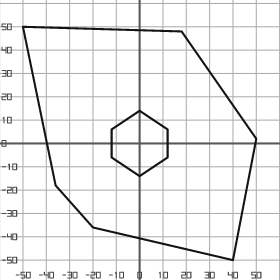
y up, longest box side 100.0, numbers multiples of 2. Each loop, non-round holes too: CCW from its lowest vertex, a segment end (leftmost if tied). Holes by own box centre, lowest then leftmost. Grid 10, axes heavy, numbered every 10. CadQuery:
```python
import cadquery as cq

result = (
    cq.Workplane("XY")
    .moveTo(40.0, -50.0)
    .lineTo(50.0, 2.0)
    .lineTo(18.0, 48.0)
    .lineTo(-50.0, 50.0)
    .lineTo(-36.0, -18.0)
    .lineTo(-20.0, -36.0)
    .close()
    .moveTo(0.0, -14.0)
    .lineTo(12.0, -6.0)
    .lineTo(12.0, 6.0)
    .lineTo(0.0, 14.0)
    .lineTo(-12.0, 6.0)
    .lineTo(-12.0, -6.0)
    .close()
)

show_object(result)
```